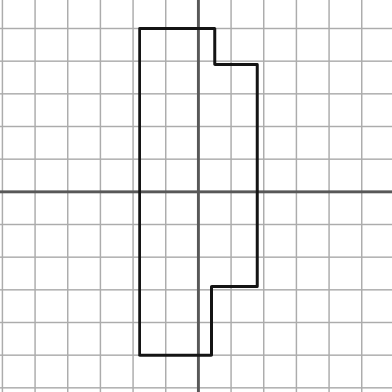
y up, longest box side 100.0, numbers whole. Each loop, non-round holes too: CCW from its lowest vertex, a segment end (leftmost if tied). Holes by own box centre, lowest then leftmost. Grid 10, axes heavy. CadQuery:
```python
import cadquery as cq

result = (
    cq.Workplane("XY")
    .moveTo(-18.0, -50.0)
    .lineTo(4.0, -50.0)
    .lineTo(4.0, -29.0)
    .lineTo(18.0, -29.0)
    .lineTo(18.0, 39.0)
    .lineTo(5.0, 39.0)
    .lineTo(5.0, 50.0)
    .lineTo(-18.0, 50.0)
    .close()
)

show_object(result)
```